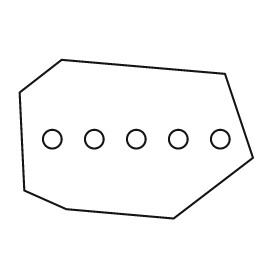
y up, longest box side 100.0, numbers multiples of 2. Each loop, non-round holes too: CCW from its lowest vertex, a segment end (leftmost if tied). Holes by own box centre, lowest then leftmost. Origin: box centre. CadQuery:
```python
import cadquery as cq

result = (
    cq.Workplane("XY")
    .moveTo(16.0, -34.0)
    .lineTo(50.0, -8.0)
    .lineTo(38.0, 28.0)
    .lineTo(-32.0, 34.0)
    .lineTo(-50.0, 20.0)
    .lineTo(-48.0, -22.0)
    .lineTo(-30.0, -30.0)
    .close()
    .moveTo(-36.0, 0.0)
    .circle(4.0)
    .moveTo(-18.0, 0.0)
    .circle(4.0)
    .moveTo(0.0, 0.0)
    .circle(4.0)
    .moveTo(18.0, 0.0)
    .circle(4.0)
    .moveTo(36.0, 0.0)
    .circle(4.0)
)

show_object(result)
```